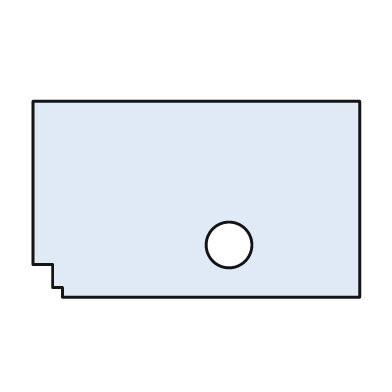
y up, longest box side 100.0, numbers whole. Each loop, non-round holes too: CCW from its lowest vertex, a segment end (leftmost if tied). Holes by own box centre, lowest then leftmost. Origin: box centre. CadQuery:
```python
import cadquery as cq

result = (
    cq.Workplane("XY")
    .moveTo(-41.0, -30.0)
    .lineTo(50.0, -30.0)
    .lineTo(50.0, 30.0)
    .lineTo(-50.0, 30.0)
    .lineTo(-50.0, -20.0)
    .lineTo(-44.0, -20.0)
    .lineTo(-44.0, -27.0)
    .lineTo(-41.0, -27.0)
    .close()
    .moveTo(10.0, -14.0)
    .circle(7.0)
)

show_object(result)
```